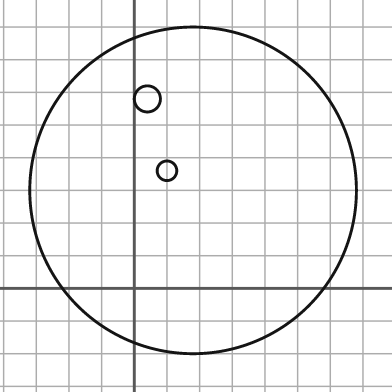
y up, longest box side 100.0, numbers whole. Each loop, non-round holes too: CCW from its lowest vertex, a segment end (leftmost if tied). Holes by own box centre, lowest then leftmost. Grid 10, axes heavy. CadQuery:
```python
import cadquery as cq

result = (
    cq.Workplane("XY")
    .moveTo(18.0, 30.0)
    .circle(50.0)
    .moveTo(10.0, 36.0)
    .circle(3.0)
    .moveTo(4.0, 58.0)
    .circle(4.0)
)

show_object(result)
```